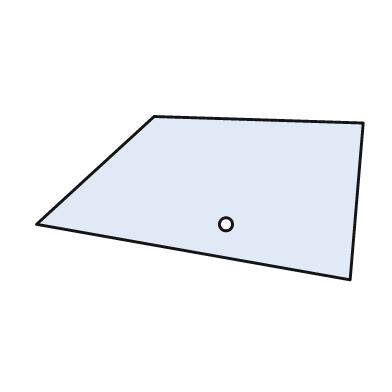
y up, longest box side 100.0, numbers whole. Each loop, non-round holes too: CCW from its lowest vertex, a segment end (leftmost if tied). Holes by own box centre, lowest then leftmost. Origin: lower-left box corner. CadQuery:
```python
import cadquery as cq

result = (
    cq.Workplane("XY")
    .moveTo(96.0, 0.0)
    .lineTo(100.0, 48.0)
    .lineTo(36.0, 50.0)
    .lineTo(0.0, 17.0)
    .close()
    .moveTo(58.0, 17.0)
    .circle(2.0)
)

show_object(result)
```